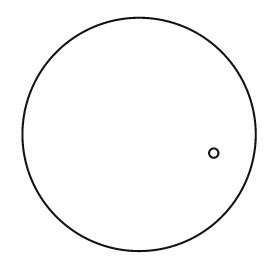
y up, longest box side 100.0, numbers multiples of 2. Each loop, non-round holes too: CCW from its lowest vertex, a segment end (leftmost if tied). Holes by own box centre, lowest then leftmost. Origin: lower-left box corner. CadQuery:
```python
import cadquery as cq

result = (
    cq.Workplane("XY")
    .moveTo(50.0, 50.0)
    .circle(50.0)
    .moveTo(82.0, 42.0)
    .circle(2.0)
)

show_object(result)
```